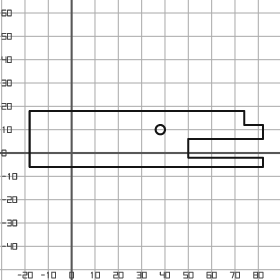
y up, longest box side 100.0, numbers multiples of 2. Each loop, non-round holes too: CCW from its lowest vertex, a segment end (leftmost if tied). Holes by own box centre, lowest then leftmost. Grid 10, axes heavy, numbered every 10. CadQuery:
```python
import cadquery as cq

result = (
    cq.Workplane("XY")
    .moveTo(-18.0, -6.0)
    .lineTo(82.0, -6.0)
    .lineTo(82.0, -2.0)
    .lineTo(50.0, -2.0)
    .lineTo(50.0, 6.0)
    .lineTo(82.0, 6.0)
    .lineTo(82.0, 12.0)
    .lineTo(74.0, 12.0)
    .lineTo(74.0, 18.0)
    .lineTo(-18.0, 18.0)
    .close()
    .moveTo(38.0, 10.0)
    .circle(2.0)
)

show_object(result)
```